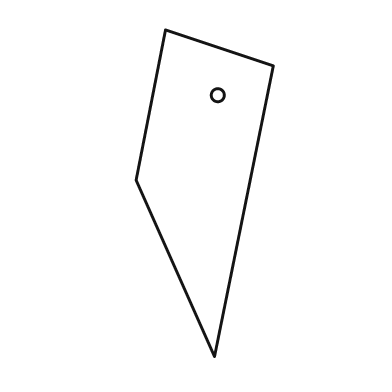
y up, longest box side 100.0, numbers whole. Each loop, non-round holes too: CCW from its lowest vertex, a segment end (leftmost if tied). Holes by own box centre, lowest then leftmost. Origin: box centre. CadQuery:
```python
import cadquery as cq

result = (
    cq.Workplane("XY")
    .moveTo(3.0, -50.0)
    .lineTo(21.0, 39.0)
    .lineTo(-12.0, 50.0)
    .lineTo(-21.0, 4.0)
    .close()
    .moveTo(4.0, 30.0)
    .circle(2.0)
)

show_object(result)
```